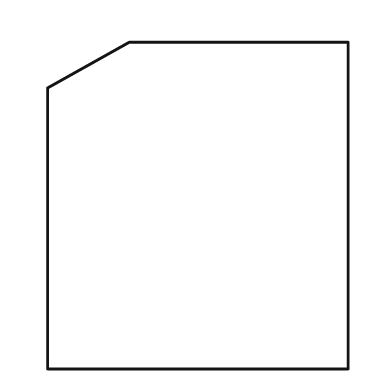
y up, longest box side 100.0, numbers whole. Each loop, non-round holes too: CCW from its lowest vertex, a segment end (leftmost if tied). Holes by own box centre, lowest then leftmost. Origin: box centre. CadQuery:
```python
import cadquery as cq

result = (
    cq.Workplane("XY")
    .moveTo(-46.0, -50.0)
    .lineTo(46.0, -50.0)
    .lineTo(46.0, 50.0)
    .lineTo(-21.0, 50.0)
    .lineTo(-46.0, 36.0)
    .close()
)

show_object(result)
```